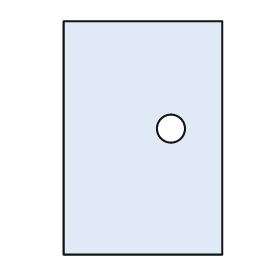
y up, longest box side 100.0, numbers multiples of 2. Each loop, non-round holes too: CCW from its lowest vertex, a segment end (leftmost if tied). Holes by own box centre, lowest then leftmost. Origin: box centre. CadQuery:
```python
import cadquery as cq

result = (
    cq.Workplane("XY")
    .moveTo(-34.0, -50.0)
    .lineTo(34.0, -50.0)
    .lineTo(34.0, 50.0)
    .lineTo(-34.0, 50.0)
    .close()
    .moveTo(12.0, 4.0)
    .circle(6.0)
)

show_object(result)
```